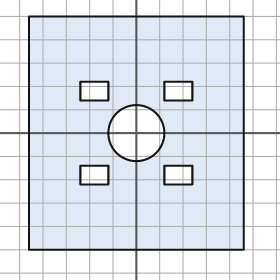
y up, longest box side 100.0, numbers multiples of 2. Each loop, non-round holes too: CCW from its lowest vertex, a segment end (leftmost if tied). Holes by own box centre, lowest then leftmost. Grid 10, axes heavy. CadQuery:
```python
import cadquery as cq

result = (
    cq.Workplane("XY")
    .moveTo(-46.0, -50.0)
    .lineTo(46.0, -50.0)
    .lineTo(46.0, 50.0)
    .lineTo(-46.0, 50.0)
    .close()
    .moveTo(-24.0, -22.0)
    .lineTo(-12.0, -22.0)
    .lineTo(-12.0, -14.0)
    .lineTo(-24.0, -14.0)
    .close()
    .moveTo(12.0, -22.0)
    .lineTo(24.0, -22.0)
    .lineTo(24.0, -14.0)
    .lineTo(12.0, -14.0)
    .close()
    .moveTo(0.0, 0.0)
    .circle(12.0)
    .moveTo(-24.0, 14.0)
    .lineTo(-12.0, 14.0)
    .lineTo(-12.0, 22.0)
    .lineTo(-24.0, 22.0)
    .close()
    .moveTo(12.0, 14.0)
    .lineTo(24.0, 14.0)
    .lineTo(24.0, 22.0)
    .lineTo(12.0, 22.0)
    .close()
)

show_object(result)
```